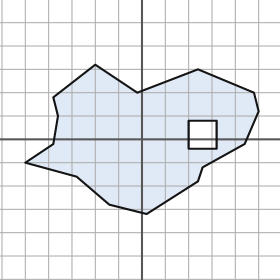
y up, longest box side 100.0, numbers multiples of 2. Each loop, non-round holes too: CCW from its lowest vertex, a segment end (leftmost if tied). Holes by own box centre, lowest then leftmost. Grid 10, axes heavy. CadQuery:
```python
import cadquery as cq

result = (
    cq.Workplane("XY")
    .moveTo(2.0, -32.0)
    .lineTo(24.0, -18.0)
    .lineTo(26.0, -12.0)
    .lineTo(44.0, -2.0)
    .lineTo(50.0, 12.0)
    .lineTo(48.0, 20.0)
    .lineTo(24.0, 30.0)
    .lineTo(-2.0, 20.0)
    .lineTo(-20.0, 32.0)
    .lineTo(-38.0, 18.0)
    .lineTo(-36.0, 10.0)
    .lineTo(-38.0, -2.0)
    .lineTo(-50.0, -10.0)
    .lineTo(-28.0, -16.0)
    .lineTo(-14.0, -28.0)
    .close()
    .moveTo(20.0, -4.0)
    .lineTo(32.0, -4.0)
    .lineTo(32.0, 8.0)
    .lineTo(20.0, 8.0)
    .close()
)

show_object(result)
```